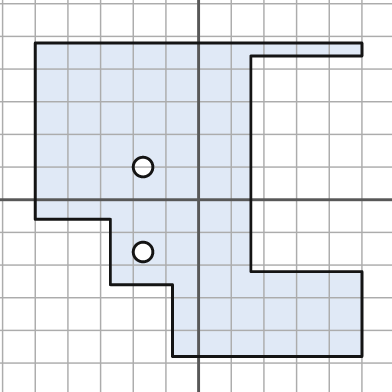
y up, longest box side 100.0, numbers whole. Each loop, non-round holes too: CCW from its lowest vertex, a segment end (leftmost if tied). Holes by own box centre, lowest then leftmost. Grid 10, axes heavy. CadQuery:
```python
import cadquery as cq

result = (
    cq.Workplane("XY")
    .moveTo(-8.0, -48.0)
    .lineTo(50.0, -48.0)
    .lineTo(50.0, -22.0)
    .lineTo(16.0, -22.0)
    .lineTo(16.0, 44.0)
    .lineTo(50.0, 44.0)
    .lineTo(50.0, 48.0)
    .lineTo(-50.0, 48.0)
    .lineTo(-50.0, -6.0)
    .lineTo(-27.0, -6.0)
    .lineTo(-27.0, -26.0)
    .lineTo(-8.0, -26.0)
    .close()
    .moveTo(-17.0, -16.0)
    .circle(3.0)
    .moveTo(-17.0, 10.0)
    .circle(3.0)
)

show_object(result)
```